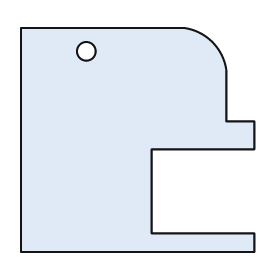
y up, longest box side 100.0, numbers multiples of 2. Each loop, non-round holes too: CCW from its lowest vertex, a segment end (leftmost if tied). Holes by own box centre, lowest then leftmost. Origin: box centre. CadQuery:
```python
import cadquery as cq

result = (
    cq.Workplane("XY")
    .moveTo(-50.0, -48.0)
    .lineTo(50.0, -48.0)
    .lineTo(50.0, -40.0)
    .lineTo(6.0, -40.0)
    .lineTo(6.0, -4.0)
    .lineTo(50.0, -4.0)
    .lineTo(50.0, 8.0)
    .lineTo(38.0, 8.0)
    .lineTo(38.0, 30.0)
    .threePointArc((32.0, 42.0), (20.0, 48.0))
    .lineTo(-50.0, 48.0)
    .close()
    .moveTo(-22.0, 38.0)
    .circle(4.0)
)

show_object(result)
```